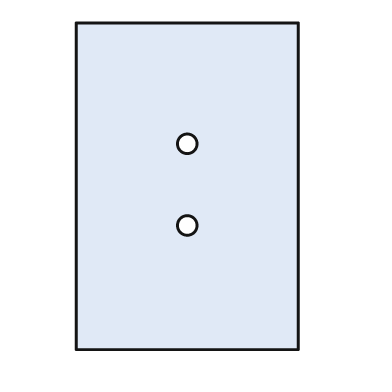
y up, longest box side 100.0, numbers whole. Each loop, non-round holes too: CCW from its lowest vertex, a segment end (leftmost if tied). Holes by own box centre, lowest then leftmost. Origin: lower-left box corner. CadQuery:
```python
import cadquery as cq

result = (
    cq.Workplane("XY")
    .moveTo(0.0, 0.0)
    .lineTo(68.0, 0.0)
    .lineTo(68.0, 100.0)
    .lineTo(0.0, 100.0)
    .close()
    .moveTo(34.0, 38.0)
    .circle(3.0)
    .moveTo(34.0, 63.0)
    .circle(3.0)
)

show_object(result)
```